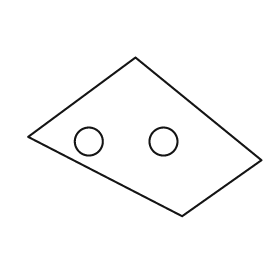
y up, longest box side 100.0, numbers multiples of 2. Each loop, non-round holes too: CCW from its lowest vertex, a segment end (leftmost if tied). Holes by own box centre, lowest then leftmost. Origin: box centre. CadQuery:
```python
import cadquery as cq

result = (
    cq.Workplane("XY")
    .moveTo(16.0, -34.0)
    .lineTo(50.0, -10.0)
    .lineTo(-4.0, 34.0)
    .lineTo(-50.0, 0.0)
    .close()
    .moveTo(-24.0, -2.0)
    .circle(6.0)
    .moveTo(8.0, -2.0)
    .circle(6.0)
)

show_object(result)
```